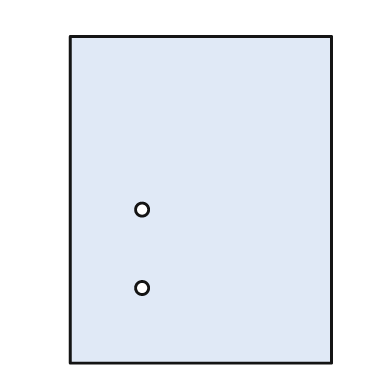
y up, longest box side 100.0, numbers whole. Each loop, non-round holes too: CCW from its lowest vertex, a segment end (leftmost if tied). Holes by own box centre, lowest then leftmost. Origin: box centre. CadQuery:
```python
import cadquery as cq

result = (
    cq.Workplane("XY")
    .moveTo(-40.0, -50.0)
    .lineTo(40.0, -50.0)
    .lineTo(40.0, 50.0)
    .lineTo(-40.0, 50.0)
    .close()
    .moveTo(-18.0, -27.0)
    .circle(2.0)
    .moveTo(-18.0, -3.0)
    .circle(2.0)
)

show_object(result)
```